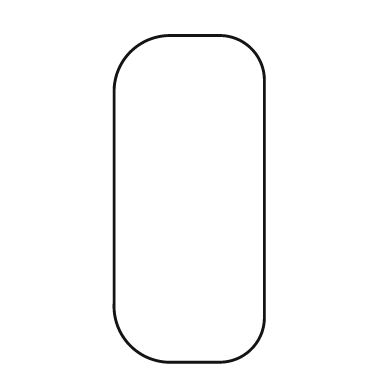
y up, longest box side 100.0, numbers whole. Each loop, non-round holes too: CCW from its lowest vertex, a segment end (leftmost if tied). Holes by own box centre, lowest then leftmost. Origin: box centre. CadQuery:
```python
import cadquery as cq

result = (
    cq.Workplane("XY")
    .moveTo(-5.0, -50.0)
    .lineTo(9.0, -50.0)
    .threePointArc((19.0, -46.0), (23.0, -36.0))
    .lineTo(23.0, 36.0)
    .threePointArc((19.0, 46.0), (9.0, 50.0))
    .lineTo(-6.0, 50.0)
    .threePointArc((-18.0, 45.0), (-23.0, 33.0))
    .lineTo(-23.0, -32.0)
    .threePointArc((-18.0, -45.0), (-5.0, -50.0))
    .close()
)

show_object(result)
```